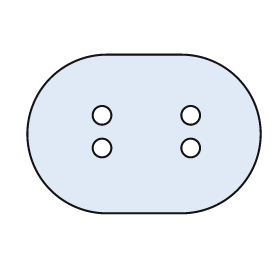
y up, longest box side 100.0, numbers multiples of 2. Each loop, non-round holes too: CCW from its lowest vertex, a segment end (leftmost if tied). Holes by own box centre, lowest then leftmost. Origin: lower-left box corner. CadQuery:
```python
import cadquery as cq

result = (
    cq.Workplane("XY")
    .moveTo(34.0, 0.0)
    .lineTo(66.0, 0.0)
    .threePointArc((100.0, 34.0), (66.0, 68.0))
    .lineTo(34.0, 68.0)
    .threePointArc((0.0, 34.0), (34.0, 0.0))
    .close()
    .moveTo(32.0, 28.0)
    .circle(4.0)
    .moveTo(70.0, 28.0)
    .circle(4.0)
    .moveTo(32.0, 42.0)
    .circle(4.0)
    .moveTo(70.0, 42.0)
    .circle(4.0)
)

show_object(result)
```